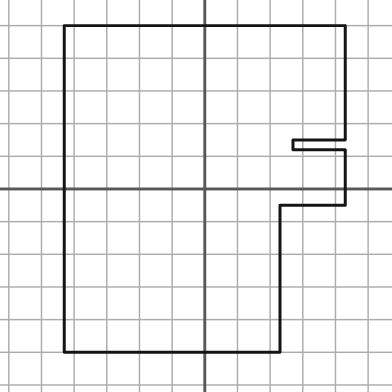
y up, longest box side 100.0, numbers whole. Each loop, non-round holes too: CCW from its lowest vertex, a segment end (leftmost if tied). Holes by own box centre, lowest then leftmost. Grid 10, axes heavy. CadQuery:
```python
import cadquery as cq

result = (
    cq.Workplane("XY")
    .moveTo(-43.0, -50.0)
    .lineTo(23.0, -50.0)
    .lineTo(23.0, -5.0)
    .lineTo(43.0, -5.0)
    .lineTo(43.0, 12.0)
    .lineTo(27.0, 12.0)
    .lineTo(27.0, 15.0)
    .lineTo(43.0, 15.0)
    .lineTo(43.0, 50.0)
    .lineTo(-43.0, 50.0)
    .close()
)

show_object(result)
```